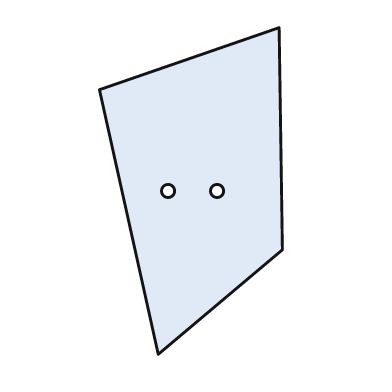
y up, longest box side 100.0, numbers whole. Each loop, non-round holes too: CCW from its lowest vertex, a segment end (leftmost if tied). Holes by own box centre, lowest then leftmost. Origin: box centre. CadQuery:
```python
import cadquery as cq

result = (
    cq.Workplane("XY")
    .moveTo(-10.0, -50.0)
    .lineTo(28.0, -18.0)
    .lineTo(27.0, 50.0)
    .lineTo(-28.0, 31.0)
    .close()
    .moveTo(-7.0, 0.0)
    .circle(2.0)
    .moveTo(8.0, 0.0)
    .circle(2.0)
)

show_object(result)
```